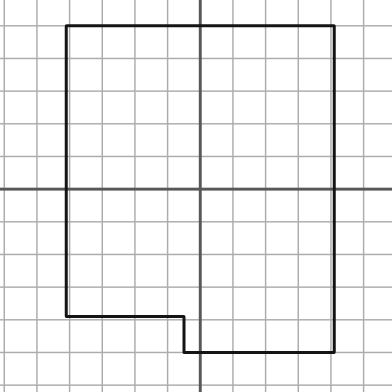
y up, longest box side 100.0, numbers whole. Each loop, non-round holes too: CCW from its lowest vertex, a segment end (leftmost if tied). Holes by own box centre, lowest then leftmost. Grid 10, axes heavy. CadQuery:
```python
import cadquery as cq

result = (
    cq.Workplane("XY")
    .moveTo(-5.0, -50.0)
    .lineTo(41.0, -50.0)
    .lineTo(41.0, 50.0)
    .lineTo(-41.0, 50.0)
    .lineTo(-41.0, -39.0)
    .lineTo(-5.0, -39.0)
    .close()
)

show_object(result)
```